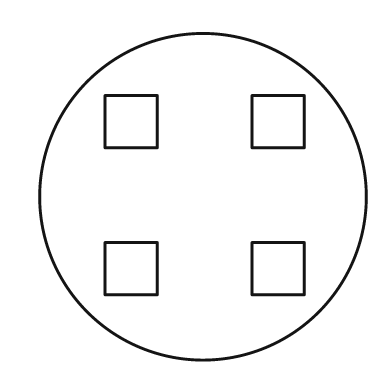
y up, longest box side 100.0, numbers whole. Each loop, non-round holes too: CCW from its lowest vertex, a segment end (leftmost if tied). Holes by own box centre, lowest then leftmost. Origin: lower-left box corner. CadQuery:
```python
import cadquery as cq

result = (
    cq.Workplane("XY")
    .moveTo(50.0, 50.0)
    .circle(50.0)
    .moveTo(20.0, 20.0)
    .lineTo(36.0, 20.0)
    .lineTo(36.0, 36.0)
    .lineTo(20.0, 36.0)
    .close()
    .moveTo(65.0, 20.0)
    .lineTo(81.0, 20.0)
    .lineTo(81.0, 36.0)
    .lineTo(65.0, 36.0)
    .close()
    .moveTo(20.0, 65.0)
    .lineTo(36.0, 65.0)
    .lineTo(36.0, 81.0)
    .lineTo(20.0, 81.0)
    .close()
    .moveTo(65.0, 65.0)
    .lineTo(81.0, 65.0)
    .lineTo(81.0, 81.0)
    .lineTo(65.0, 81.0)
    .close()
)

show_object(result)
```